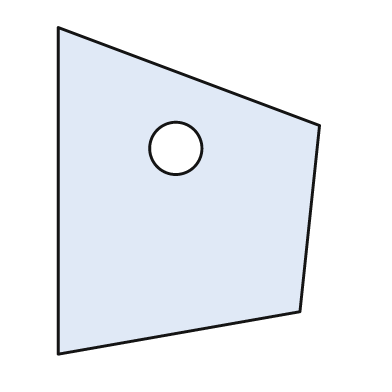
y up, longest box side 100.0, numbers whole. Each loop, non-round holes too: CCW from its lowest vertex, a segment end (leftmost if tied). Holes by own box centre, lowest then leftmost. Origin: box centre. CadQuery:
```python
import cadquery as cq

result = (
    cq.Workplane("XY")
    .moveTo(-40.0, -50.0)
    .lineTo(34.0, -37.0)
    .lineTo(40.0, 20.0)
    .lineTo(-40.0, 50.0)
    .close()
    .moveTo(-4.0, 13.0)
    .circle(8.0)
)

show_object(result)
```